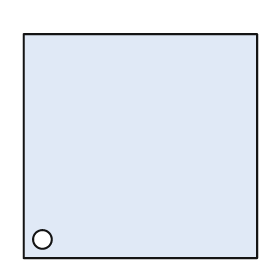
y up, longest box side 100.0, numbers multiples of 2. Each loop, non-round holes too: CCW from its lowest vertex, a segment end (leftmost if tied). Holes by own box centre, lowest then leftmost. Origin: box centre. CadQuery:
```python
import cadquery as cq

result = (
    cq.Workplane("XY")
    .moveTo(-50.0, -48.0)
    .lineTo(50.0, -48.0)
    .lineTo(50.0, 48.0)
    .lineTo(-50.0, 48.0)
    .close()
    .moveTo(-42.0, -40.0)
    .circle(4.0)
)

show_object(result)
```